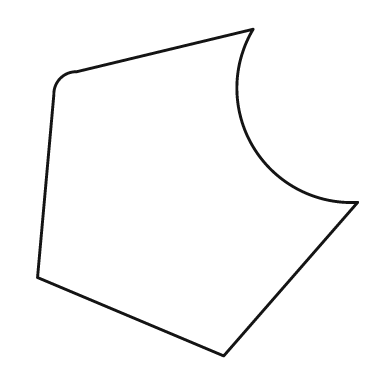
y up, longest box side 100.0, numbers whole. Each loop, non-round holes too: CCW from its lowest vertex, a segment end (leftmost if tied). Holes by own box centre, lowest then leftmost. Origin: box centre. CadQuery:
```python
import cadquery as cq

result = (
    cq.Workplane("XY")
    .moveTo(8.0, -50.0)
    .lineTo(49.0, -3.0)
    .threePointArc((17.0, 14.0), (17.0, 50.0))
    .lineTo(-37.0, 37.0)
    .threePointArc((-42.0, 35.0), (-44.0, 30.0))
    .lineTo(-49.0, -26.0)
    .close()
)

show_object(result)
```